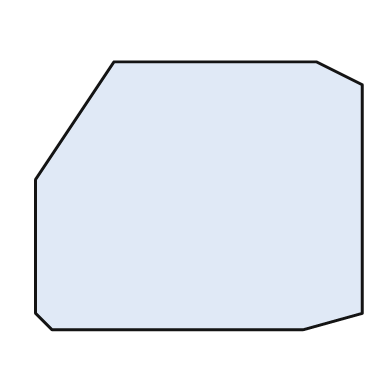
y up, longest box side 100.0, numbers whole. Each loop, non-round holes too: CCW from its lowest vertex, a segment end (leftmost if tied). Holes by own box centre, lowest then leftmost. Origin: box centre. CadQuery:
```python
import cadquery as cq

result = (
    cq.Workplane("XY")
    .moveTo(-45.0, -41.0)
    .lineTo(32.0, -41.0)
    .lineTo(50.0, -36.0)
    .lineTo(50.0, 34.0)
    .lineTo(36.0, 41.0)
    .lineTo(-26.0, 41.0)
    .lineTo(-50.0, 5.0)
    .lineTo(-50.0, -36.0)
    .close()
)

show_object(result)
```